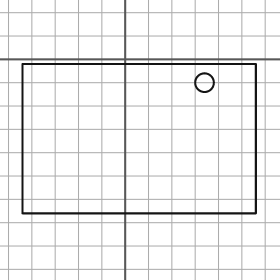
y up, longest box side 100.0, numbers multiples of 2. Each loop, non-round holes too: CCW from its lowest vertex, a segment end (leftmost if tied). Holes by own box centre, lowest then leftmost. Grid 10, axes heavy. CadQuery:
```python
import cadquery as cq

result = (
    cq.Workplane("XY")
    .moveTo(-44.0, -66.0)
    .lineTo(56.0, -66.0)
    .lineTo(56.0, -2.0)
    .lineTo(-44.0, -2.0)
    .close()
    .moveTo(34.0, -10.0)
    .circle(4.0)
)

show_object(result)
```